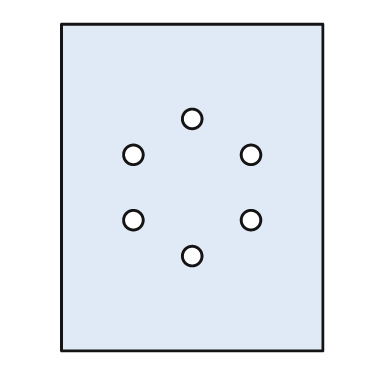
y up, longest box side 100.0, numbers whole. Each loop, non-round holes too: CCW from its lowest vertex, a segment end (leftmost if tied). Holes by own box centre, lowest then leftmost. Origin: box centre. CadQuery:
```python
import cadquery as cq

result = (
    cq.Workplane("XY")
    .moveTo(-40.0, -50.0)
    .lineTo(40.0, -50.0)
    .lineTo(40.0, 50.0)
    .lineTo(-40.0, 50.0)
    .close()
    .moveTo(0.0, -21.0)
    .circle(3.0)
    .moveTo(-18.0, -10.0)
    .circle(3.0)
    .moveTo(18.0, -10.0)
    .circle(3.0)
    .moveTo(-18.0, 10.0)
    .circle(3.0)
    .moveTo(18.0, 10.0)
    .circle(3.0)
    .moveTo(0.0, 21.0)
    .circle(3.0)
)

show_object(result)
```